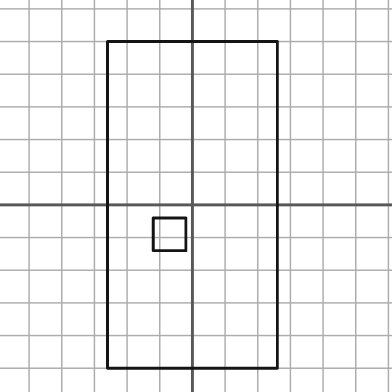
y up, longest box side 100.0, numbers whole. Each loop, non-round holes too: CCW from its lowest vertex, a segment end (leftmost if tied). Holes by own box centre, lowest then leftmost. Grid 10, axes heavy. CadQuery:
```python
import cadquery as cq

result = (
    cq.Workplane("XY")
    .moveTo(-26.0, -50.0)
    .lineTo(26.0, -50.0)
    .lineTo(26.0, 50.0)
    .lineTo(-26.0, 50.0)
    .close()
    .moveTo(-12.0, -14.0)
    .lineTo(-2.0, -14.0)
    .lineTo(-2.0, -4.0)
    .lineTo(-12.0, -4.0)
    .close()
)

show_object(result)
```